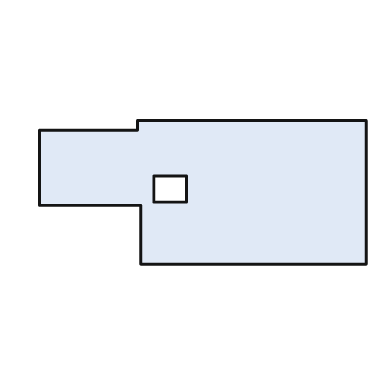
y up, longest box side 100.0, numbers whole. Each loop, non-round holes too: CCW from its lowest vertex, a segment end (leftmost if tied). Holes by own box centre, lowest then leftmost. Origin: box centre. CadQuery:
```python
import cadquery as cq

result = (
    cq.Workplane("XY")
    .moveTo(-19.0, -22.0)
    .lineTo(50.0, -22.0)
    .lineTo(50.0, 22.0)
    .lineTo(-20.0, 22.0)
    .lineTo(-20.0, 19.0)
    .lineTo(-50.0, 19.0)
    .lineTo(-50.0, -4.0)
    .lineTo(-19.0, -4.0)
    .close()
    .moveTo(-15.0, -3.0)
    .lineTo(-5.0, -3.0)
    .lineTo(-5.0, 5.0)
    .lineTo(-15.0, 5.0)
    .close()
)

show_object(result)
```